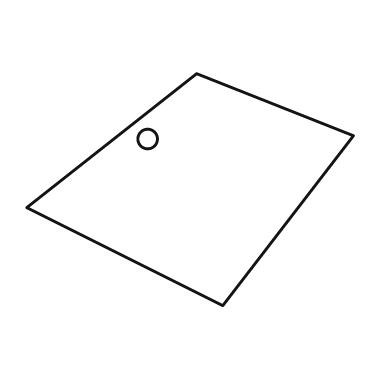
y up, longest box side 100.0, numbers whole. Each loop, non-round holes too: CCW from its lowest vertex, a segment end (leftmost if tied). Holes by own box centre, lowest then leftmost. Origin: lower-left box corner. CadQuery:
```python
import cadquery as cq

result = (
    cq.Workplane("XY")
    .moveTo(60.0, 0.0)
    .lineTo(100.0, 52.0)
    .lineTo(52.0, 71.0)
    .lineTo(0.0, 30.0)
    .close()
    .moveTo(37.0, 51.0)
    .circle(3.0)
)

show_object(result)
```